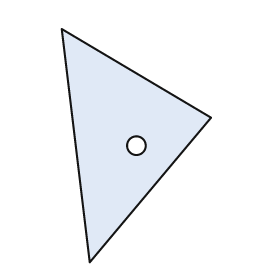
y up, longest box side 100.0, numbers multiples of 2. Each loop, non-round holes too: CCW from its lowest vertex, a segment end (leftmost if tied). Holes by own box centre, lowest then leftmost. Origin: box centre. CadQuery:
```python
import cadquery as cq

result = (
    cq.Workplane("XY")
    .moveTo(-20.0, -50.0)
    .lineTo(32.0, 12.0)
    .lineTo(-32.0, 50.0)
    .close()
    .moveTo(0.0, 0.0)
    .circle(4.0)
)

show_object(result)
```